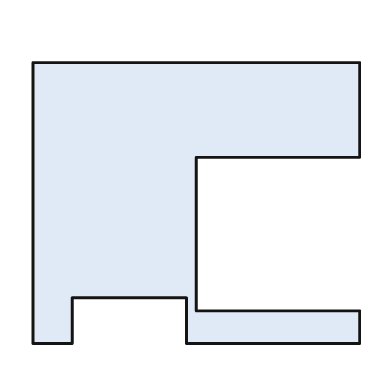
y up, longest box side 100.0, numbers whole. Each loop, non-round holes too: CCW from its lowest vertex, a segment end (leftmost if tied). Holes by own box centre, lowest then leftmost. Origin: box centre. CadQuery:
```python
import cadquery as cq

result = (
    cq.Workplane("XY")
    .moveTo(-50.0, -43.0)
    .lineTo(-38.0, -43.0)
    .lineTo(-38.0, -29.0)
    .lineTo(-3.0, -29.0)
    .lineTo(-3.0, -43.0)
    .lineTo(50.0, -43.0)
    .lineTo(50.0, -33.0)
    .lineTo(0.0, -33.0)
    .lineTo(0.0, 14.0)
    .lineTo(50.0, 14.0)
    .lineTo(50.0, 43.0)
    .lineTo(-50.0, 43.0)
    .close()
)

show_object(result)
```